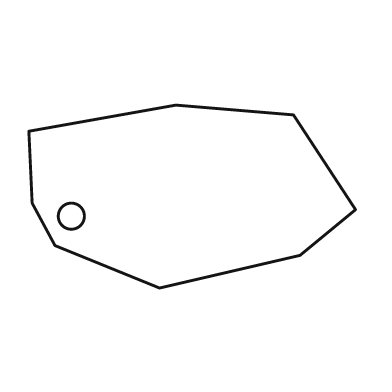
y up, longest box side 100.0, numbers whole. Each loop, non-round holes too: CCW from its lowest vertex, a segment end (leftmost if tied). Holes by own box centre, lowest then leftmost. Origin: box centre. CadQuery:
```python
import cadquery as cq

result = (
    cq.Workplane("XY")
    .moveTo(-10.0, -28.0)
    .lineTo(33.0, -18.0)
    .lineTo(50.0, -4.0)
    .lineTo(31.0, 25.0)
    .lineTo(-5.0, 28.0)
    .lineTo(-50.0, 20.0)
    .lineTo(-49.0, -2.0)
    .lineTo(-42.0, -15.0)
    .close()
    .moveTo(-37.0, -6.0)
    .circle(4.0)
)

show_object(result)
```